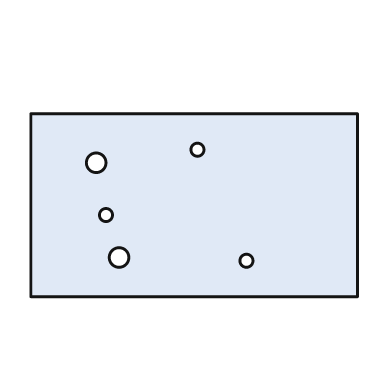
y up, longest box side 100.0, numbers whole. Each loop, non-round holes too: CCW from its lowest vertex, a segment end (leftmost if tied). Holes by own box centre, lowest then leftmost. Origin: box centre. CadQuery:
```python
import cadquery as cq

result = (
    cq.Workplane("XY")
    .moveTo(-50.0, -28.0)
    .lineTo(50.0, -28.0)
    .lineTo(50.0, 28.0)
    .lineTo(-50.0, 28.0)
    .close()
    .moveTo(16.0, -17.0)
    .circle(2.0)
    .moveTo(-23.0, -16.0)
    .circle(3.0)
    .moveTo(-27.0, -3.0)
    .circle(2.0)
    .moveTo(-30.0, 13.0)
    .circle(3.0)
    .moveTo(1.0, 17.0)
    .circle(2.0)
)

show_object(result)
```